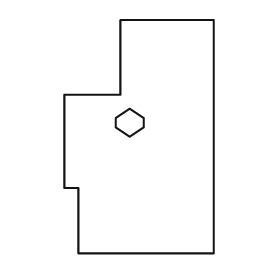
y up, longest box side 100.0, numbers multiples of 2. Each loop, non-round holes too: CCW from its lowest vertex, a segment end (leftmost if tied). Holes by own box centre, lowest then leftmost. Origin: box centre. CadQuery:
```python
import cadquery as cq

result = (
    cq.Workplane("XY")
    .moveTo(-26.0, -50.0)
    .lineTo(32.0, -50.0)
    .lineTo(32.0, 50.0)
    .lineTo(-8.0, 50.0)
    .lineTo(-8.0, 18.0)
    .lineTo(-32.0, 18.0)
    .lineTo(-32.0, -22.0)
    .lineTo(-26.0, -22.0)
    .close()
    .moveTo(-4.0, 0.0)
    .lineTo(2.0, 4.0)
    .lineTo(2.0, 8.0)
    .lineTo(-4.0, 12.0)
    .lineTo(-10.0, 8.0)
    .lineTo(-10.0, 4.0)
    .close()
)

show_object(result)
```